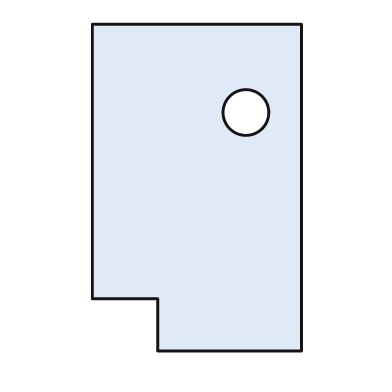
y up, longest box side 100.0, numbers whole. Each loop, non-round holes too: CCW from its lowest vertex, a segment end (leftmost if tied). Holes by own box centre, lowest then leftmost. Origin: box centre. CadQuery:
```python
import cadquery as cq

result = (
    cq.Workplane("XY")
    .moveTo(-12.0, -50.0)
    .lineTo(32.0, -50.0)
    .lineTo(32.0, 50.0)
    .lineTo(-32.0, 50.0)
    .lineTo(-32.0, -34.0)
    .lineTo(-12.0, -34.0)
    .close()
    .moveTo(15.0, 23.0)
    .circle(7.0)
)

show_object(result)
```